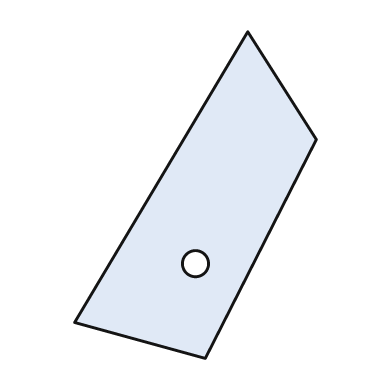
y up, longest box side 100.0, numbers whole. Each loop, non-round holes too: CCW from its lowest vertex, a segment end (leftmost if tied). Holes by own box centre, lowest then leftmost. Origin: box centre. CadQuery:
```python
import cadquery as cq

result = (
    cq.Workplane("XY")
    .moveTo(3.0, -50.0)
    .lineTo(37.0, 17.0)
    .lineTo(16.0, 50.0)
    .lineTo(-37.0, -39.0)
    .close()
    .moveTo(0.0, -21.0)
    .circle(4.0)
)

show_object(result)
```